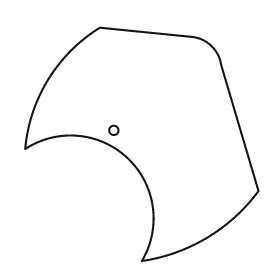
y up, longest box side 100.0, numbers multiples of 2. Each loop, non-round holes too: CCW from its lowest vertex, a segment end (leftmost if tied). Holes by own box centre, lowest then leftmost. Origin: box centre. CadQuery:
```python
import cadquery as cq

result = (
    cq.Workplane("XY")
    .moveTo(0.0, -50.0)
    .threePointArc((28.0, -40.0), (50.0, -20.0))
    .lineTo(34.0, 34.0)
    .threePointArc((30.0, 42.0), (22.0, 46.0))
    .lineTo(-18.0, 50.0)
    .threePointArc((-40.0, 28.0), (-50.0, -2.0))
    .threePointArc((-6.0, -6.0), (0.0, -50.0))
    .close()
    .moveTo(-12.0, 6.0)
    .circle(2.0)
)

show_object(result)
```